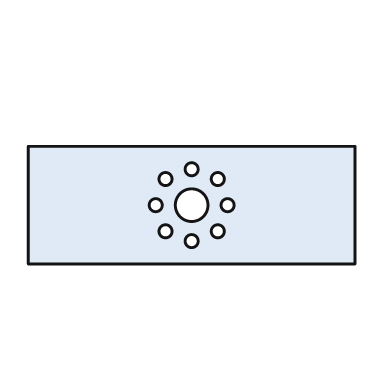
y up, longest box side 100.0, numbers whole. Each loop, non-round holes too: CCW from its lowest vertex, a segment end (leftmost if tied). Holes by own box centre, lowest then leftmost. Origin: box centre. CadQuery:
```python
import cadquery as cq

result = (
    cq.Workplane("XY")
    .moveTo(-50.0, -18.0)
    .lineTo(50.0, -18.0)
    .lineTo(50.0, 18.0)
    .lineTo(-50.0, 18.0)
    .close()
    .moveTo(0.0, -11.0)
    .circle(2.0)
    .moveTo(-8.0, -8.0)
    .circle(2.0)
    .moveTo(8.0, -8.0)
    .circle(2.0)
    .moveTo(-11.0, 0.0)
    .circle(2.0)
    .moveTo(0.0, 0.0)
    .circle(5.0)
    .moveTo(11.0, 0.0)
    .circle(2.0)
    .moveTo(-8.0, 8.0)
    .circle(2.0)
    .moveTo(8.0, 8.0)
    .circle(2.0)
    .moveTo(0.0, 11.0)
    .circle(2.0)
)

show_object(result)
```